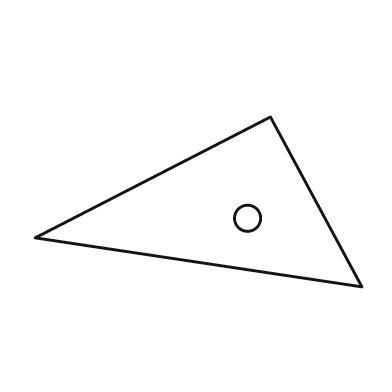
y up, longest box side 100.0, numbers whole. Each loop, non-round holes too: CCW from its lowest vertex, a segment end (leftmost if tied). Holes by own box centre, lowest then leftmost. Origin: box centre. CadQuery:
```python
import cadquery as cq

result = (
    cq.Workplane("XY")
    .moveTo(50.0, -26.0)
    .lineTo(22.0, 26.0)
    .lineTo(-50.0, -11.0)
    .close()
    .moveTo(15.0, -5.0)
    .circle(4.0)
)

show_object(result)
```